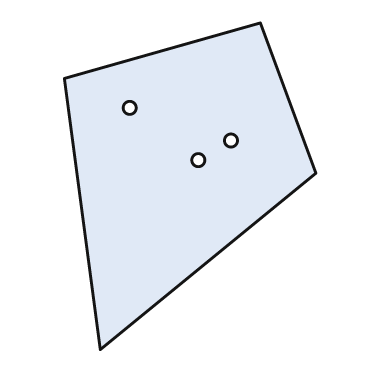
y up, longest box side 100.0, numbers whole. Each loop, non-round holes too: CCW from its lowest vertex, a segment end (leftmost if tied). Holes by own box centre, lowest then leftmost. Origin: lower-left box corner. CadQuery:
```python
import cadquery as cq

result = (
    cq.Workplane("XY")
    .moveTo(11.0, 0.0)
    .lineTo(77.0, 54.0)
    .lineTo(60.0, 100.0)
    .lineTo(0.0, 83.0)
    .close()
    .moveTo(41.0, 58.0)
    .circle(2.0)
    .moveTo(51.0, 64.0)
    .circle(2.0)
    .moveTo(20.0, 74.0)
    .circle(2.0)
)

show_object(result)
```